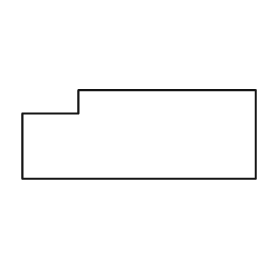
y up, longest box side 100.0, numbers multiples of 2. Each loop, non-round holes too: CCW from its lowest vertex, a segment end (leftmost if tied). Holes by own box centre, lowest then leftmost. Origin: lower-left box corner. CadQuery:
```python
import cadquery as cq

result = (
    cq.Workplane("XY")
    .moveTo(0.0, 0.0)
    .lineTo(100.0, 0.0)
    .lineTo(100.0, 38.0)
    .lineTo(24.0, 38.0)
    .lineTo(24.0, 28.0)
    .lineTo(0.0, 28.0)
    .close()
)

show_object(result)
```